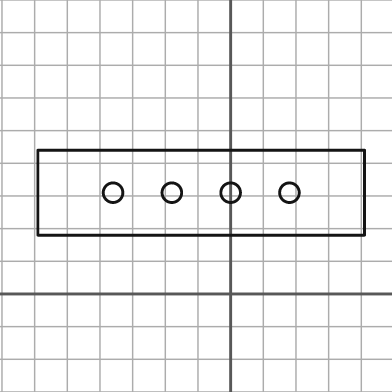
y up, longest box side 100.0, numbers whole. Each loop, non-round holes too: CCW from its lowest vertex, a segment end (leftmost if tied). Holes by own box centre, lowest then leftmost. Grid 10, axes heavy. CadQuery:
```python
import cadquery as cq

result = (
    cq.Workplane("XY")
    .moveTo(-59.0, 18.0)
    .lineTo(41.0, 18.0)
    .lineTo(41.0, 44.0)
    .lineTo(-59.0, 44.0)
    .close()
    .moveTo(-36.0, 31.0)
    .circle(3.0)
    .moveTo(-18.0, 31.0)
    .circle(3.0)
    .moveTo(0.0, 31.0)
    .circle(3.0)
    .moveTo(18.0, 31.0)
    .circle(3.0)
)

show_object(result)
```